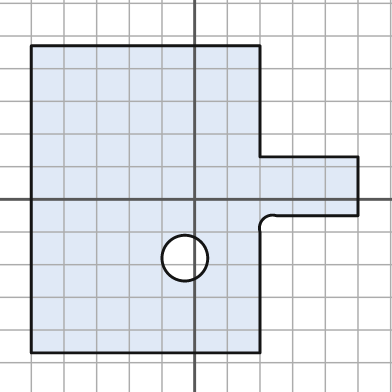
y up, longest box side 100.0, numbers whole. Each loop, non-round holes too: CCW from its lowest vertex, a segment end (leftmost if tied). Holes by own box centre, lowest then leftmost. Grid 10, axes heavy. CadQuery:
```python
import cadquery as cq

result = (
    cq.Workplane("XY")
    .moveTo(-50.0, -47.0)
    .lineTo(20.0, -47.0)
    .lineTo(20.0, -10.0)
    .threePointArc((21.0, -6.0), (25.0, -5.0))
    .lineTo(50.0, -5.0)
    .lineTo(50.0, 13.0)
    .lineTo(20.0, 13.0)
    .lineTo(20.0, 47.0)
    .lineTo(-50.0, 47.0)
    .close()
    .moveTo(-3.0, -18.0)
    .circle(7.0)
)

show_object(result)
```